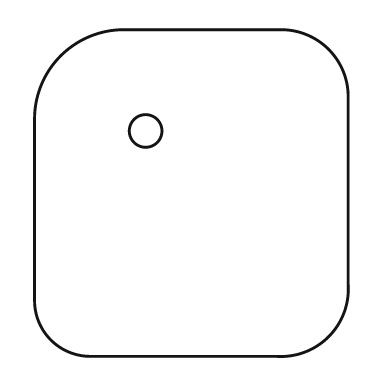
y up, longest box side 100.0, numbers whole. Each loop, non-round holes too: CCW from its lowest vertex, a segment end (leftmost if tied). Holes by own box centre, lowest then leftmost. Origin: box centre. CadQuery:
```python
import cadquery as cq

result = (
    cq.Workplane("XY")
    .moveTo(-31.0, -50.0)
    .lineTo(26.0, -50.0)
    .threePointArc((42.0, -44.0), (48.0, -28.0))
    .lineTo(48.0, 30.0)
    .threePointArc((42.0, 44.0), (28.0, 50.0))
    .lineTo(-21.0, 50.0)
    .threePointArc((-40.0, 42.0), (-48.0, 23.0))
    .lineTo(-48.0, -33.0)
    .threePointArc((-43.0, -45.0), (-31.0, -50.0))
    .close()
    .moveTo(-14.0, 19.0)
    .circle(5.0)
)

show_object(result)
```